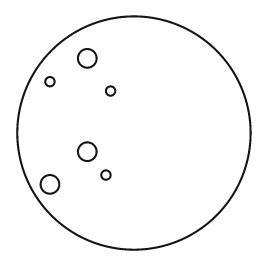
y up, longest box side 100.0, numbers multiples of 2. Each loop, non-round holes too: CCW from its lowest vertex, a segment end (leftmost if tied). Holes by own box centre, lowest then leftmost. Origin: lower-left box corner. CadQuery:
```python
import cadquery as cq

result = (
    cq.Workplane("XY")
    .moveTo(50.0, 50.0)
    .circle(50.0)
    .moveTo(14.0, 28.0)
    .circle(4.0)
    .moveTo(38.0, 32.0)
    .circle(2.0)
    .moveTo(30.0, 42.0)
    .circle(4.0)
    .moveTo(40.0, 68.0)
    .circle(2.0)
    .moveTo(14.0, 72.0)
    .circle(2.0)
    .moveTo(30.0, 82.0)
    .circle(4.0)
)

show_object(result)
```